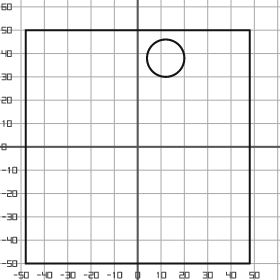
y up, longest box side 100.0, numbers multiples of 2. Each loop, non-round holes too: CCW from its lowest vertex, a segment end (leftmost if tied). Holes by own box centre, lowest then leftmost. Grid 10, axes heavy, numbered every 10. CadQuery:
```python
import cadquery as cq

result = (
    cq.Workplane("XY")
    .moveTo(-48.0, -50.0)
    .lineTo(48.0, -50.0)
    .lineTo(48.0, 50.0)
    .lineTo(-48.0, 50.0)
    .close()
    .moveTo(12.0, 38.0)
    .circle(8.0)
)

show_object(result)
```